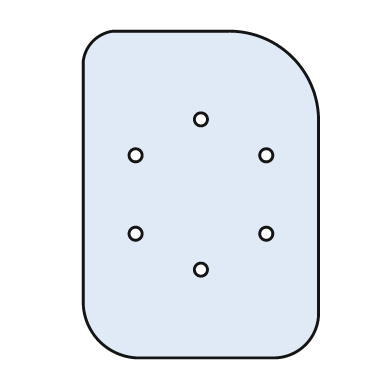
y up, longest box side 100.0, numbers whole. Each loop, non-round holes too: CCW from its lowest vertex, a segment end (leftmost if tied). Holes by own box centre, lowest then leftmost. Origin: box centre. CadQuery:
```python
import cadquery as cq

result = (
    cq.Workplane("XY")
    .moveTo(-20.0, -50.0)
    .lineTo(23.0, -50.0)
    .threePointArc((32.0, -46.0), (36.0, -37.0))
    .lineTo(36.0, 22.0)
    .threePointArc((28.0, 42.0), (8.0, 50.0))
    .lineTo(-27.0, 50.0)
    .threePointArc((-33.0, 47.0), (-36.0, 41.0))
    .lineTo(-36.0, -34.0)
    .threePointArc((-31.0, -45.0), (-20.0, -50.0))
    .close()
    .moveTo(0.0, -23.0)
    .circle(2.0)
    .moveTo(-20.0, -12.0)
    .circle(2.0)
    .moveTo(20.0, -12.0)
    .circle(2.0)
    .moveTo(-20.0, 12.0)
    .circle(2.0)
    .moveTo(20.0, 12.0)
    .circle(2.0)
    .moveTo(0.0, 23.0)
    .circle(2.0)
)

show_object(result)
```